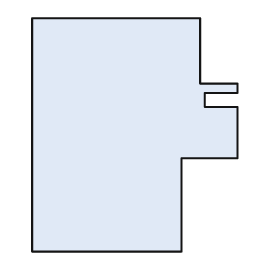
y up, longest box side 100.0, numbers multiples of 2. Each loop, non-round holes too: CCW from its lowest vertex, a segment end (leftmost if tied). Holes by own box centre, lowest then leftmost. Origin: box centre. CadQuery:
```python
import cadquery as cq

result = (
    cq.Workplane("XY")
    .moveTo(-44.0, -50.0)
    .lineTo(20.0, -50.0)
    .lineTo(20.0, -10.0)
    .lineTo(44.0, -10.0)
    .lineTo(44.0, 12.0)
    .lineTo(30.0, 12.0)
    .lineTo(30.0, 18.0)
    .lineTo(44.0, 18.0)
    .lineTo(44.0, 22.0)
    .lineTo(28.0, 22.0)
    .lineTo(28.0, 50.0)
    .lineTo(-44.0, 50.0)
    .close()
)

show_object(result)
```